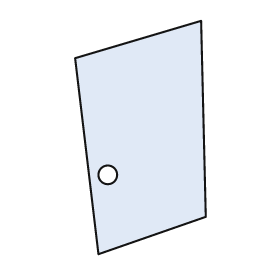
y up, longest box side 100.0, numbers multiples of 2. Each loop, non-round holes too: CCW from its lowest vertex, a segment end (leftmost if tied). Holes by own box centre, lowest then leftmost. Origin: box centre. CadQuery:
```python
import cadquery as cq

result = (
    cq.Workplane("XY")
    .moveTo(-18.0, -50.0)
    .lineTo(28.0, -34.0)
    .lineTo(26.0, 50.0)
    .lineTo(-28.0, 34.0)
    .close()
    .moveTo(-14.0, -16.0)
    .circle(4.0)
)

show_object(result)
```